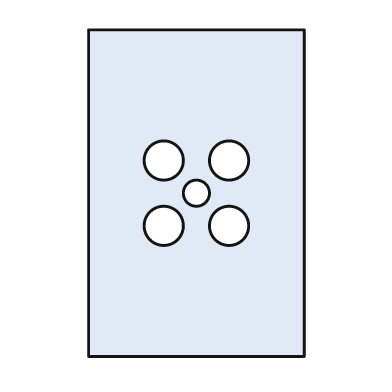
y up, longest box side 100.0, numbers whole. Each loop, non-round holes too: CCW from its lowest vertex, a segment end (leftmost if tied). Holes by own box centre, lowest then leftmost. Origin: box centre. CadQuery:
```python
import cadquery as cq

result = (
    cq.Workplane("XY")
    .moveTo(-33.0, -50.0)
    .lineTo(33.0, -50.0)
    .lineTo(33.0, 50.0)
    .lineTo(-33.0, 50.0)
    .close()
    .moveTo(-10.0, -10.0)
    .circle(6.0)
    .moveTo(10.0, -10.0)
    .circle(6.0)
    .moveTo(0.0, 0.0)
    .circle(4.0)
    .moveTo(-10.0, 10.0)
    .circle(6.0)
    .moveTo(10.0, 10.0)
    .circle(6.0)
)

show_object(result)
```